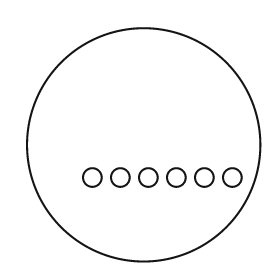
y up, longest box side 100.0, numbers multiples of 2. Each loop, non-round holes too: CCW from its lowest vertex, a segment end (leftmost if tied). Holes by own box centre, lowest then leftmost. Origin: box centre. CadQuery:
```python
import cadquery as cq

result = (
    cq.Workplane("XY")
    .moveTo(0.0, 0.0)
    .circle(50.0)
    .moveTo(-22.0, -14.0)
    .circle(4.0)
    .moveTo(-10.0, -14.0)
    .circle(4.0)
    .moveTo(2.0, -14.0)
    .circle(4.0)
    .moveTo(14.0, -14.0)
    .circle(4.0)
    .moveTo(26.0, -14.0)
    .circle(4.0)
    .moveTo(38.0, -14.0)
    .circle(4.0)
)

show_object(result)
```